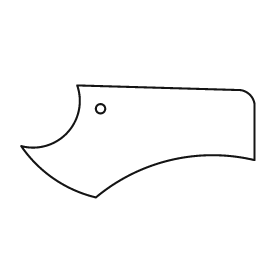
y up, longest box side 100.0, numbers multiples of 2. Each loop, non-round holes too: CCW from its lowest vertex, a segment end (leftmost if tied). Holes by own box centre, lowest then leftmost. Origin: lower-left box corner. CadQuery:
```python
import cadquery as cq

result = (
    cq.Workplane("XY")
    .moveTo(32.0, 0.0)
    .threePointArc((64.0, 16.0), (100.0, 16.0))
    .lineTo(100.0, 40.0)
    .threePointArc((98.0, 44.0), (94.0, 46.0))
    .lineTo(24.0, 48.0)
    .threePointArc((20.0, 28.0), (0.0, 22.0))
    .threePointArc((14.0, 8.0), (32.0, 0.0))
    .close()
    .moveTo(34.0, 38.0)
    .circle(2.0)
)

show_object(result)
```